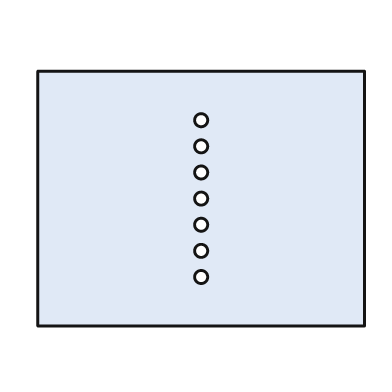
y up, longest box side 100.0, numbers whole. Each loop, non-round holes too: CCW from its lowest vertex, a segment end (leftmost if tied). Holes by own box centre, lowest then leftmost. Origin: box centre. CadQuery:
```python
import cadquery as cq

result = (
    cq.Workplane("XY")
    .moveTo(-50.0, -39.0)
    .lineTo(50.0, -39.0)
    .lineTo(50.0, 39.0)
    .lineTo(-50.0, 39.0)
    .close()
    .moveTo(0.0, -24.0)
    .circle(2.0)
    .moveTo(0.0, -16.0)
    .circle(2.0)
    .moveTo(0.0, -8.0)
    .circle(2.0)
    .moveTo(0.0, 0.0)
    .circle(2.0)
    .moveTo(0.0, 8.0)
    .circle(2.0)
    .moveTo(0.0, 16.0)
    .circle(2.0)
    .moveTo(0.0, 24.0)
    .circle(2.0)
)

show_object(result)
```